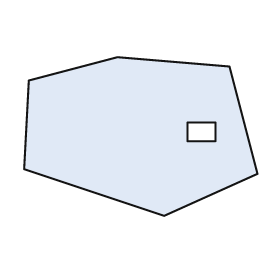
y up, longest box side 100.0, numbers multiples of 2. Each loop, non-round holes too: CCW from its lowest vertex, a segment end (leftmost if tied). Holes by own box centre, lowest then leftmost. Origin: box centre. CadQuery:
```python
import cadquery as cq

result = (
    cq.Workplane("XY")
    .moveTo(10.0, -34.0)
    .lineTo(50.0, -16.0)
    .lineTo(38.0, 30.0)
    .lineTo(-10.0, 34.0)
    .lineTo(-48.0, 24.0)
    .lineTo(-50.0, -14.0)
    .close()
    .moveTo(20.0, -2.0)
    .lineTo(32.0, -2.0)
    .lineTo(32.0, 6.0)
    .lineTo(20.0, 6.0)
    .close()
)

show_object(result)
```